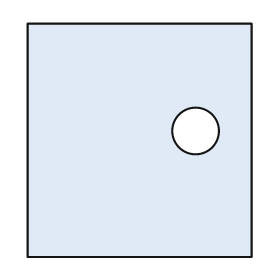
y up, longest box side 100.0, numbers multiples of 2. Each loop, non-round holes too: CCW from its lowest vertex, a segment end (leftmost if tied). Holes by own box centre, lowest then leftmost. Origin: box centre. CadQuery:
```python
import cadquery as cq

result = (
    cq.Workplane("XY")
    .moveTo(-48.0, -50.0)
    .lineTo(48.0, -50.0)
    .lineTo(48.0, 50.0)
    .lineTo(-48.0, 50.0)
    .close()
    .moveTo(24.0, 4.0)
    .circle(10.0)
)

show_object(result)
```